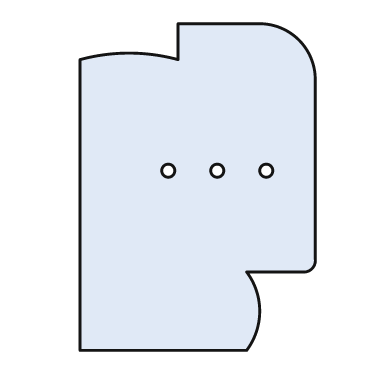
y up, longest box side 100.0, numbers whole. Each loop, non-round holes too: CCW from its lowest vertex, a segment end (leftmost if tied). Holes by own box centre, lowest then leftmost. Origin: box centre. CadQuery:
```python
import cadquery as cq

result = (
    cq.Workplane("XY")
    .moveTo(-36.0, -50.0)
    .lineTo(15.0, -50.0)
    .threePointArc((19.0, -38.0), (15.0, -26.0))
    .lineTo(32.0, -26.0)
    .threePointArc((35.0, -25.0), (36.0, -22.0))
    .lineTo(36.0, 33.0)
    .threePointArc((31.0, 45.0), (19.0, 50.0))
    .lineTo(-6.0, 50.0)
    .lineTo(-6.0, 39.0)
    .threePointArc((-21.0, 41.0), (-36.0, 39.0))
    .close()
    .moveTo(-9.0, 5.0)
    .circle(2.0)
    .moveTo(6.0, 5.0)
    .circle(2.0)
    .moveTo(21.0, 5.0)
    .circle(2.0)
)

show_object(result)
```